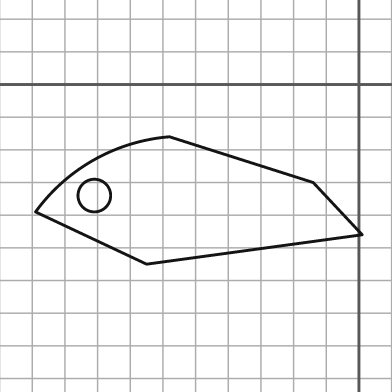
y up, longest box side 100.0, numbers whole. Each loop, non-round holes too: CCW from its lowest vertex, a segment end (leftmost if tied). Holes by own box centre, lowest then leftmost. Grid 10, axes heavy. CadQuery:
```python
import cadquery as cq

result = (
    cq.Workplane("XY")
    .moveTo(-65.0, -55.0)
    .lineTo(1.0, -46.0)
    .lineTo(-14.0, -30.0)
    .lineTo(-58.0, -16.0)
    .threePointArc((-81.0, -23.0), (-99.0, -39.0))
    .close()
    .moveTo(-81.0, -34.0)
    .circle(5.0)
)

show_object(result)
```